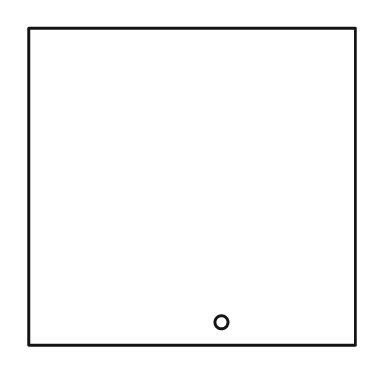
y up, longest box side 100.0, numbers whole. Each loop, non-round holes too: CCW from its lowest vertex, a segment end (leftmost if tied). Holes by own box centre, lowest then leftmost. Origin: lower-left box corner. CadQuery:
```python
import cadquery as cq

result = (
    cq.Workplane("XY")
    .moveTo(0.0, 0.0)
    .lineTo(100.0, 0.0)
    .lineTo(100.0, 97.0)
    .lineTo(0.0, 97.0)
    .close()
    .moveTo(59.0, 7.0)
    .circle(2.0)
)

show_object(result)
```